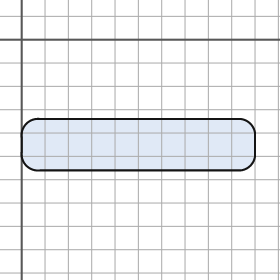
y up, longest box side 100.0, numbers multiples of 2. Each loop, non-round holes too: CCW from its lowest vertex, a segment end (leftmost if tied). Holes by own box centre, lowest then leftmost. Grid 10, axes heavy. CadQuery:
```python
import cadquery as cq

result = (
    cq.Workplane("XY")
    .moveTo(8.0, -56.0)
    .lineTo(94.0, -56.0)
    .threePointArc((98.0, -54.0), (100.0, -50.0))
    .lineTo(100.0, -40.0)
    .threePointArc((98.0, -36.0), (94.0, -34.0))
    .lineTo(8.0, -34.0)
    .threePointArc((2.0, -36.0), (0.0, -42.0))
    .lineTo(0.0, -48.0)
    .threePointArc((2.0, -54.0), (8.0, -56.0))
    .close()
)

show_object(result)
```